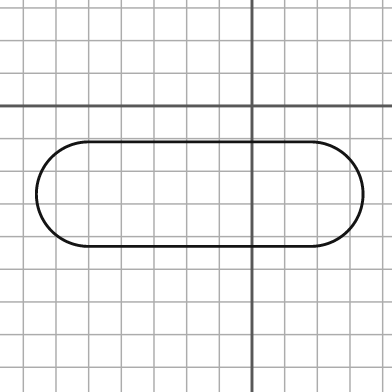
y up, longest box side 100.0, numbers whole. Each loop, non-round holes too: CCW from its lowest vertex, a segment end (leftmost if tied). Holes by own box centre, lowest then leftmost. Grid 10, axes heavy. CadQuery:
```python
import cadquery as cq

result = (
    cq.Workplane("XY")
    .moveTo(-50.0, -43.0)
    .lineTo(18.0, -43.0)
    .threePointArc((34.0, -27.0), (18.0, -11.0))
    .lineTo(-50.0, -11.0)
    .threePointArc((-66.0, -27.0), (-50.0, -43.0))
    .close()
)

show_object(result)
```